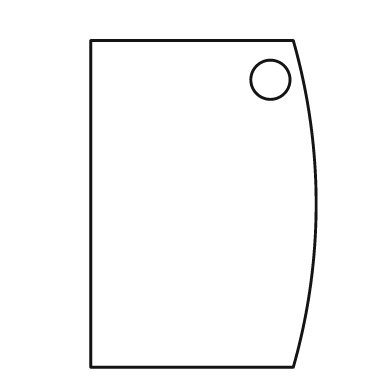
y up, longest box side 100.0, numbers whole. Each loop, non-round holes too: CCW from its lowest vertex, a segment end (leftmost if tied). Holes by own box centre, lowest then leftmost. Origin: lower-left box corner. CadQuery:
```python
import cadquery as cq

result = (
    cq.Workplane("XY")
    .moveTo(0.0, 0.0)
    .lineTo(62.0, 0.0)
    .threePointArc((69.0, 50.0), (62.0, 100.0))
    .lineTo(0.0, 100.0)
    .close()
    .moveTo(55.0, 88.0)
    .circle(6.0)
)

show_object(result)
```